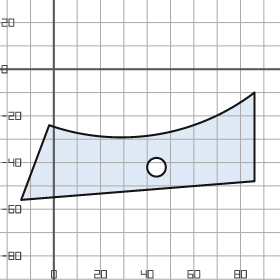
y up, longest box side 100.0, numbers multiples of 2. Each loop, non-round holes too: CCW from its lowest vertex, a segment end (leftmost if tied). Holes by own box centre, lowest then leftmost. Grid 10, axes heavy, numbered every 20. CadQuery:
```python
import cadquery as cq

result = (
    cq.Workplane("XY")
    .moveTo(-14.0, -56.0)
    .lineTo(86.0, -48.0)
    .lineTo(86.0, -10.0)
    .threePointArc((44.0, -28.0), (-2.0, -24.0))
    .close()
    .moveTo(44.0, -42.0)
    .circle(4.0)
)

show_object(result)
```